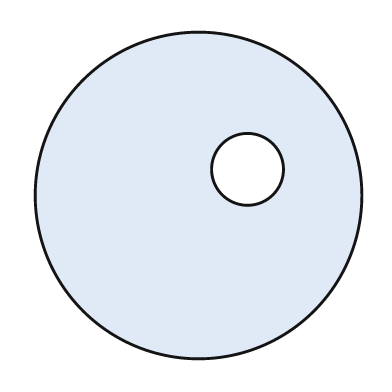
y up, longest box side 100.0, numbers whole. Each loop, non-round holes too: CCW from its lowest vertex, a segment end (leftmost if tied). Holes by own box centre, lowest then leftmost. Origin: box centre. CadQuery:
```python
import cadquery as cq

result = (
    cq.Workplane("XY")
    .moveTo(0.0, 0.0)
    .circle(50.0)
    .moveTo(15.0, 8.0)
    .circle(11.0)
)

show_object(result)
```